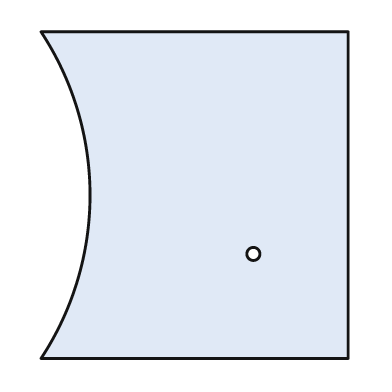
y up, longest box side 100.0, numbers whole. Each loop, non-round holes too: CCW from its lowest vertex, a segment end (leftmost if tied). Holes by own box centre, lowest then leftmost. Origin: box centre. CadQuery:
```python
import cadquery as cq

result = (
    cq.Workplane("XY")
    .moveTo(-47.0, -50.0)
    .lineTo(47.0, -50.0)
    .lineTo(47.0, 50.0)
    .lineTo(-47.0, 50.0)
    .threePointArc((-32.0, 0.0), (-47.0, -50.0))
    .close()
    .moveTo(18.0, -18.0)
    .circle(2.0)
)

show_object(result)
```